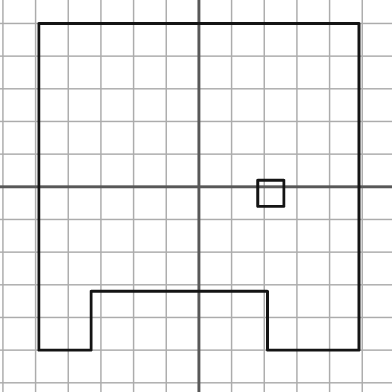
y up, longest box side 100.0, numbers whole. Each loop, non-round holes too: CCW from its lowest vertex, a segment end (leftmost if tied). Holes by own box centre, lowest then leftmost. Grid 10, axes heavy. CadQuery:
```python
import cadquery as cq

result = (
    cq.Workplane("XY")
    .moveTo(-49.0, -50.0)
    .lineTo(-33.0, -50.0)
    .lineTo(-33.0, -32.0)
    .lineTo(21.0, -32.0)
    .lineTo(21.0, -50.0)
    .lineTo(49.0, -50.0)
    .lineTo(49.0, 50.0)
    .lineTo(-49.0, 50.0)
    .close()
    .moveTo(18.0, -6.0)
    .lineTo(26.0, -6.0)
    .lineTo(26.0, 2.0)
    .lineTo(18.0, 2.0)
    .close()
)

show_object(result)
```